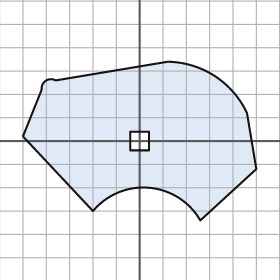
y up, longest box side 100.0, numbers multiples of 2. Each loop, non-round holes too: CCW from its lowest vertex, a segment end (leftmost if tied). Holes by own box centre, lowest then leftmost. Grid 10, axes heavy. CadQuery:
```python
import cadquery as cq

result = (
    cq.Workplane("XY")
    .moveTo(26.0, -34.0)
    .lineTo(50.0, -12.0)
    .lineTo(46.0, 12.0)
    .threePointArc((32.0, 28.0), (12.0, 34.0))
    .lineTo(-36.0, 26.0)
    .threePointArc((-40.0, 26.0), (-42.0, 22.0))
    .lineTo(-50.0, 2.0)
    .lineTo(-20.0, -30.0)
    .threePointArc((4.0, -20.0), (26.0, -34.0))
    .close()
    .moveTo(-4.0, -4.0)
    .lineTo(4.0, -4.0)
    .lineTo(4.0, 4.0)
    .lineTo(-4.0, 4.0)
    .close()
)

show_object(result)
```